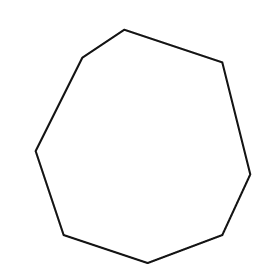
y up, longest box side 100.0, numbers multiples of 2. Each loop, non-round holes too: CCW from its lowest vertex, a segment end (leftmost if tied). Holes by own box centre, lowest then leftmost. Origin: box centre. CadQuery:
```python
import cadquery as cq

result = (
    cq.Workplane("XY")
    .moveTo(2.0, -50.0)
    .lineTo(34.0, -38.0)
    .lineTo(46.0, -12.0)
    .lineTo(34.0, 36.0)
    .lineTo(-8.0, 50.0)
    .lineTo(-26.0, 38.0)
    .lineTo(-46.0, -2.0)
    .lineTo(-34.0, -38.0)
    .close()
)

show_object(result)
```